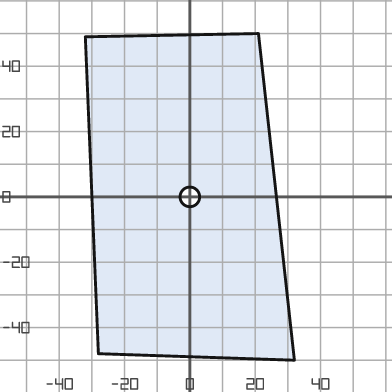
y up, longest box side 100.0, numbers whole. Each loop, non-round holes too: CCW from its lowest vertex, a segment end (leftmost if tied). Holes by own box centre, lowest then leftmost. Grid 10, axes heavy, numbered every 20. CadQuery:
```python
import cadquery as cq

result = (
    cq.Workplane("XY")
    .moveTo(32.0, -50.0)
    .lineTo(21.0, 50.0)
    .lineTo(-32.0, 49.0)
    .lineTo(-28.0, -48.0)
    .close()
    .moveTo(0.0, 0.0)
    .circle(3.0)
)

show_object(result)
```